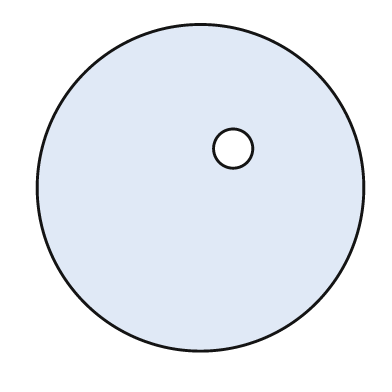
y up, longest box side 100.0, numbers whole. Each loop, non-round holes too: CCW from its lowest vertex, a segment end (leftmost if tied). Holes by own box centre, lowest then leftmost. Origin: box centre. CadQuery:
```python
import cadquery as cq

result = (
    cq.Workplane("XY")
    .moveTo(0.0, 0.0)
    .circle(50.0)
    .moveTo(10.0, 12.0)
    .circle(6.0)
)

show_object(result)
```